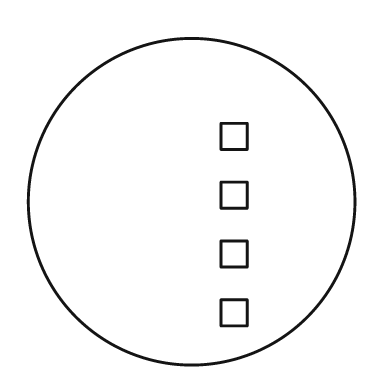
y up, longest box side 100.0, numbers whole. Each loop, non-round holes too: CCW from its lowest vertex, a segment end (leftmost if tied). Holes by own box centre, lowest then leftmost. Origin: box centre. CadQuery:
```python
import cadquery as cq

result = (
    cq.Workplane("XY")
    .moveTo(0.0, 0.0)
    .circle(50.0)
    .moveTo(9.0, -38.0)
    .lineTo(17.0, -38.0)
    .lineTo(17.0, -30.0)
    .lineTo(9.0, -30.0)
    .close()
    .moveTo(9.0, -20.0)
    .lineTo(17.0, -20.0)
    .lineTo(17.0, -12.0)
    .lineTo(9.0, -12.0)
    .close()
    .moveTo(9.0, -2.0)
    .lineTo(17.0, -2.0)
    .lineTo(17.0, 6.0)
    .lineTo(9.0, 6.0)
    .close()
    .moveTo(9.0, 16.0)
    .lineTo(17.0, 16.0)
    .lineTo(17.0, 24.0)
    .lineTo(9.0, 24.0)
    .close()
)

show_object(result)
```